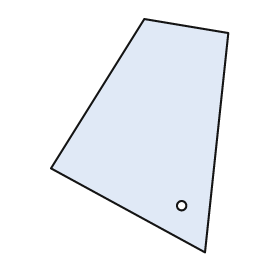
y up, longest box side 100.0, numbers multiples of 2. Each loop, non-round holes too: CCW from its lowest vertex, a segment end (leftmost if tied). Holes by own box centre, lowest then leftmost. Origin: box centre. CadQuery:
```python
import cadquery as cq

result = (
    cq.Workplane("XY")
    .moveTo(28.0, -50.0)
    .lineTo(38.0, 44.0)
    .lineTo(2.0, 50.0)
    .lineTo(-38.0, -14.0)
    .close()
    .moveTo(18.0, -30.0)
    .circle(2.0)
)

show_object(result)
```